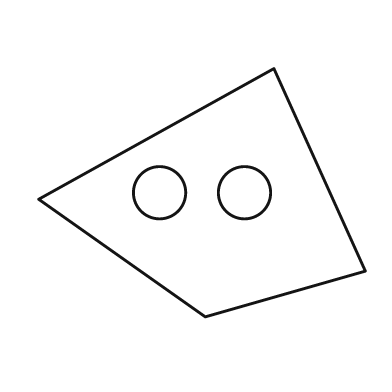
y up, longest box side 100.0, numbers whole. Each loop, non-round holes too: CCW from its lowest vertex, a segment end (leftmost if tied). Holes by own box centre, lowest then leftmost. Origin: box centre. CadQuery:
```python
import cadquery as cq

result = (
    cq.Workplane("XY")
    .moveTo(1.0, -38.0)
    .lineTo(50.0, -24.0)
    .lineTo(22.0, 38.0)
    .lineTo(-50.0, -2.0)
    .close()
    .moveTo(-13.0, 0.0)
    .circle(8.0)
    .moveTo(13.0, 0.0)
    .circle(8.0)
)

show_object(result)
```